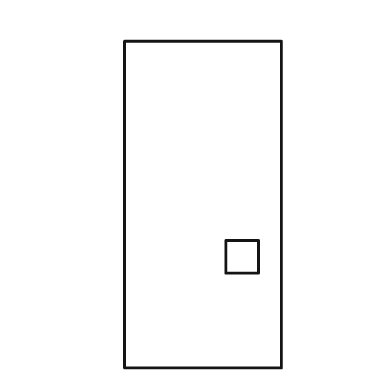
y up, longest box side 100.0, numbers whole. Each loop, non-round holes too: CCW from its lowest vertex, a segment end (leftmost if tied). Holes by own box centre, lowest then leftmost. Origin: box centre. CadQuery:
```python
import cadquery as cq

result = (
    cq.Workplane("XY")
    .moveTo(-24.0, -50.0)
    .lineTo(24.0, -50.0)
    .lineTo(24.0, 50.0)
    .lineTo(-24.0, 50.0)
    .close()
    .moveTo(7.0, -21.0)
    .lineTo(17.0, -21.0)
    .lineTo(17.0, -11.0)
    .lineTo(7.0, -11.0)
    .close()
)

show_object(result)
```